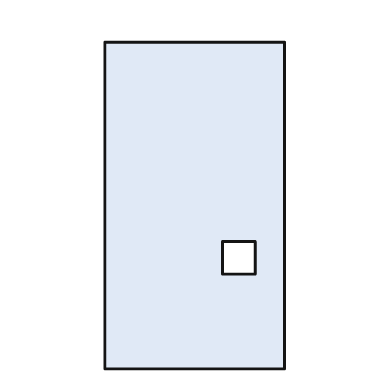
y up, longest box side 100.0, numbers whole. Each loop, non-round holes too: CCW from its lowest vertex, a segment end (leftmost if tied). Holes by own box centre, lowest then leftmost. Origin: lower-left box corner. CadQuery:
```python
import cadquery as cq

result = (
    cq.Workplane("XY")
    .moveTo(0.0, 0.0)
    .lineTo(55.0, 0.0)
    .lineTo(55.0, 100.0)
    .lineTo(0.0, 100.0)
    .close()
    .moveTo(36.0, 29.0)
    .lineTo(46.0, 29.0)
    .lineTo(46.0, 39.0)
    .lineTo(36.0, 39.0)
    .close()
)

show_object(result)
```